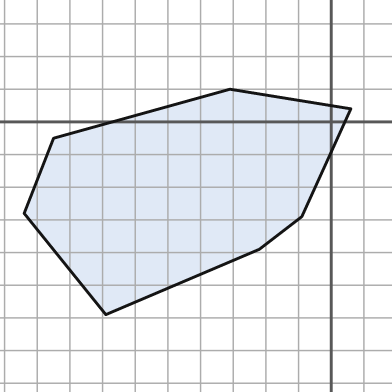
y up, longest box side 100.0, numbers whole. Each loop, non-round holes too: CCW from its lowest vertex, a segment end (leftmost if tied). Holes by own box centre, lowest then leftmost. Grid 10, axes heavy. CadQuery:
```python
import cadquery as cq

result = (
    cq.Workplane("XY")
    .moveTo(-69.0, -59.0)
    .lineTo(-22.0, -39.0)
    .lineTo(-9.0, -29.0)
    .lineTo(6.0, 4.0)
    .lineTo(-31.0, 10.0)
    .lineTo(-85.0, -5.0)
    .lineTo(-94.0, -28.0)
    .close()
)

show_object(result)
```